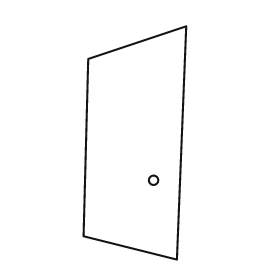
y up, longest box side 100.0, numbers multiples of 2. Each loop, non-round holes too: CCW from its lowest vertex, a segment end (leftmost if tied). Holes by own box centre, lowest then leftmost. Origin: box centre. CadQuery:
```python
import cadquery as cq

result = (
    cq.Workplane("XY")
    .moveTo(18.0, -50.0)
    .lineTo(22.0, 50.0)
    .lineTo(-20.0, 36.0)
    .lineTo(-22.0, -40.0)
    .close()
    .moveTo(8.0, -16.0)
    .circle(2.0)
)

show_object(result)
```